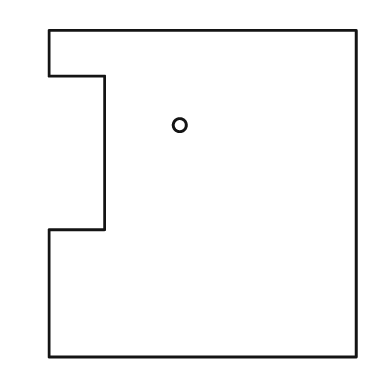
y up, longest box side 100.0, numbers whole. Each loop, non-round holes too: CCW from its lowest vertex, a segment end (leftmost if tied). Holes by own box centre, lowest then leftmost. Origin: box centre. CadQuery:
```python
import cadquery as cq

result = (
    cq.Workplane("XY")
    .moveTo(-47.0, -50.0)
    .lineTo(47.0, -50.0)
    .lineTo(47.0, 50.0)
    .lineTo(-47.0, 50.0)
    .lineTo(-47.0, 36.0)
    .lineTo(-30.0, 36.0)
    .lineTo(-30.0, -11.0)
    .lineTo(-47.0, -11.0)
    .close()
    .moveTo(-7.0, 21.0)
    .circle(2.0)
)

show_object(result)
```